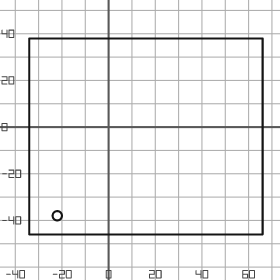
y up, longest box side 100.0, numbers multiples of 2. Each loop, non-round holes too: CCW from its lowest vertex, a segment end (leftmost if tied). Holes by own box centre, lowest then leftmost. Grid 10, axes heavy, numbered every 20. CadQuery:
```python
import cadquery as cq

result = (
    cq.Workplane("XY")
    .moveTo(-34.0, -46.0)
    .lineTo(66.0, -46.0)
    .lineTo(66.0, 38.0)
    .lineTo(-34.0, 38.0)
    .close()
    .moveTo(-22.0, -38.0)
    .circle(2.0)
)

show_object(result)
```